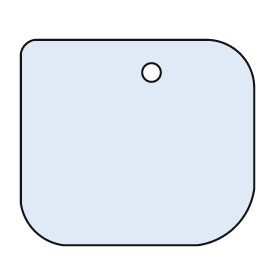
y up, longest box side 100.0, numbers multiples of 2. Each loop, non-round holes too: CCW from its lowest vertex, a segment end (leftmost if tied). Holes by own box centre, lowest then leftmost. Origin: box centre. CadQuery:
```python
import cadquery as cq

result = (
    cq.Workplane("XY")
    .moveTo(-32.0, -44.0)
    .lineTo(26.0, -44.0)
    .threePointArc((42.0, -36.0), (50.0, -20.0))
    .lineTo(50.0, 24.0)
    .threePointArc((44.0, 38.0), (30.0, 44.0))
    .lineTo(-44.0, 44.0)
    .threePointArc((-48.0, 42.0), (-50.0, 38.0))
    .lineTo(-50.0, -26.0)
    .threePointArc((-44.0, -38.0), (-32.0, -44.0))
    .close()
    .moveTo(6.0, 30.0)
    .circle(4.0)
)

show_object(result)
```